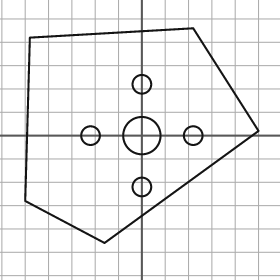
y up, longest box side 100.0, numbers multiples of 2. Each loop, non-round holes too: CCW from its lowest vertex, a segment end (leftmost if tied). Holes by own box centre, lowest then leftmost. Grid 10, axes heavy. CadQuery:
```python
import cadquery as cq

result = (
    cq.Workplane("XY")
    .moveTo(-16.0, -46.0)
    .lineTo(50.0, 2.0)
    .lineTo(22.0, 46.0)
    .lineTo(-48.0, 42.0)
    .lineTo(-50.0, -28.0)
    .close()
    .moveTo(0.0, -22.0)
    .circle(4.0)
    .moveTo(-22.0, 0.0)
    .circle(4.0)
    .moveTo(0.0, 0.0)
    .circle(8.0)
    .moveTo(22.0, 0.0)
    .circle(4.0)
    .moveTo(0.0, 22.0)
    .circle(4.0)
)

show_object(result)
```